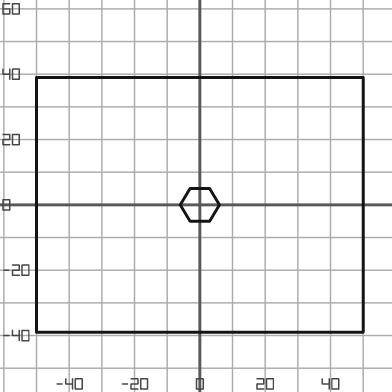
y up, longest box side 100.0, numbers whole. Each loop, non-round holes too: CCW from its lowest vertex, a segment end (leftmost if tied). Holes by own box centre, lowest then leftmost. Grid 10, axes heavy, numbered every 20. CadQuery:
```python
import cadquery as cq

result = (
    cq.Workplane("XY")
    .moveTo(-50.0, -39.0)
    .lineTo(50.0, -39.0)
    .lineTo(50.0, 39.0)
    .lineTo(-50.0, 39.0)
    .close()
    .moveTo(-3.0, -5.0)
    .lineTo(3.0, -5.0)
    .lineTo(6.0, 0.0)
    .lineTo(3.0, 5.0)
    .lineTo(-3.0, 5.0)
    .lineTo(-6.0, 0.0)
    .close()
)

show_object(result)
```